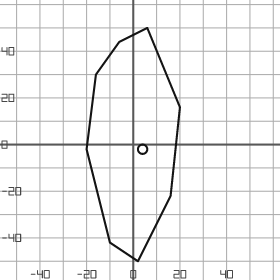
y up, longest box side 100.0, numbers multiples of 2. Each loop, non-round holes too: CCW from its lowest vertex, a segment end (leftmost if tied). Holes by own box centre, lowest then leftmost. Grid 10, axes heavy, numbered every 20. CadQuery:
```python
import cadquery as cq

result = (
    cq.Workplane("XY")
    .moveTo(2.0, -50.0)
    .lineTo(16.0, -22.0)
    .lineTo(20.0, 16.0)
    .lineTo(6.0, 50.0)
    .lineTo(-6.0, 44.0)
    .lineTo(-16.0, 30.0)
    .lineTo(-20.0, -2.0)
    .lineTo(-10.0, -42.0)
    .close()
    .moveTo(4.0, -2.0)
    .circle(2.0)
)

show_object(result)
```